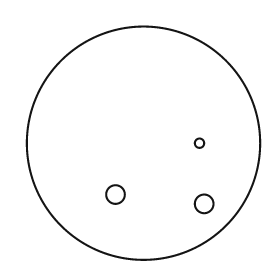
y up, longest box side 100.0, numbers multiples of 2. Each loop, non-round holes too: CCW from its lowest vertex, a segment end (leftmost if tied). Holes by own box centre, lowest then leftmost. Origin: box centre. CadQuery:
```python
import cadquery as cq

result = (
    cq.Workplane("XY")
    .moveTo(0.0, 0.0)
    .circle(50.0)
    .moveTo(26.0, -26.0)
    .circle(4.0)
    .moveTo(-12.0, -22.0)
    .circle(4.0)
    .moveTo(24.0, 0.0)
    .circle(2.0)
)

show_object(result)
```